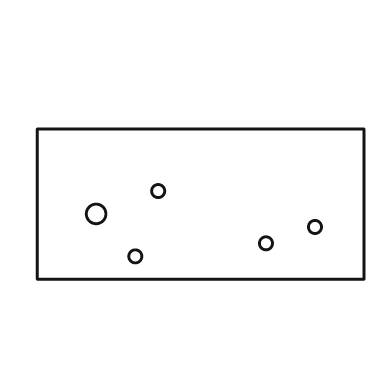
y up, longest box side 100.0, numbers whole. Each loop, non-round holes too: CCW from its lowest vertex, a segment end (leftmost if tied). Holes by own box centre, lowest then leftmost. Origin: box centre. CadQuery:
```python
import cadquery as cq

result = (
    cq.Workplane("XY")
    .moveTo(-50.0, -23.0)
    .lineTo(50.0, -23.0)
    .lineTo(50.0, 23.0)
    .lineTo(-50.0, 23.0)
    .close()
    .moveTo(-20.0, -16.0)
    .circle(2.0)
    .moveTo(20.0, -12.0)
    .circle(2.0)
    .moveTo(35.0, -7.0)
    .circle(2.0)
    .moveTo(-32.0, -3.0)
    .circle(3.0)
    .moveTo(-13.0, 4.0)
    .circle(2.0)
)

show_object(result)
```